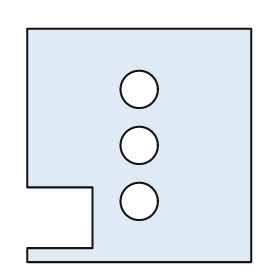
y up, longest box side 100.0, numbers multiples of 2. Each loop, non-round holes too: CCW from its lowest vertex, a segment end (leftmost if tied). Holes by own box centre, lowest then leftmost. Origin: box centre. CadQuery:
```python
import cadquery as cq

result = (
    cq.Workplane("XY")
    .moveTo(-48.0, -50.0)
    .lineTo(48.0, -50.0)
    .lineTo(48.0, 50.0)
    .lineTo(-48.0, 50.0)
    .lineTo(-48.0, -18.0)
    .lineTo(-20.0, -18.0)
    .lineTo(-20.0, -44.0)
    .lineTo(-48.0, -44.0)
    .close()
    .moveTo(0.0, -24.0)
    .circle(8.0)
    .moveTo(0.0, 0.0)
    .circle(8.0)
    .moveTo(0.0, 24.0)
    .circle(8.0)
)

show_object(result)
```